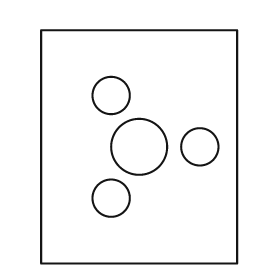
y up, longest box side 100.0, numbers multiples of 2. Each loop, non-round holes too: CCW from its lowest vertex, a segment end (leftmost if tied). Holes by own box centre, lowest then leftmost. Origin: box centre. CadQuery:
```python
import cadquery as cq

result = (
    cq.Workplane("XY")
    .moveTo(-42.0, -50.0)
    .lineTo(42.0, -50.0)
    .lineTo(42.0, 50.0)
    .lineTo(-42.0, 50.0)
    .close()
    .moveTo(-12.0, -22.0)
    .circle(8.0)
    .moveTo(0.0, 0.0)
    .circle(12.0)
    .moveTo(26.0, 0.0)
    .circle(8.0)
    .moveTo(-12.0, 22.0)
    .circle(8.0)
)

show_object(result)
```